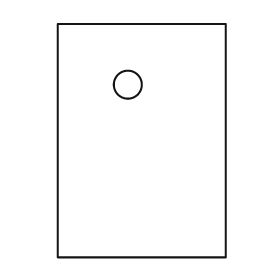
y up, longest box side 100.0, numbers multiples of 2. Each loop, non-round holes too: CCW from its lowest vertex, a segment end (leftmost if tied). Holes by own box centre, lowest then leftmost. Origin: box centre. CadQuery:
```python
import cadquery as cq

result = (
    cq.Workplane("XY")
    .moveTo(-36.0, -50.0)
    .lineTo(36.0, -50.0)
    .lineTo(36.0, 50.0)
    .lineTo(-36.0, 50.0)
    .close()
    .moveTo(-6.0, 24.0)
    .circle(6.0)
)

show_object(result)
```